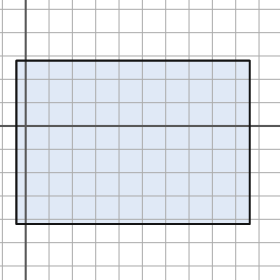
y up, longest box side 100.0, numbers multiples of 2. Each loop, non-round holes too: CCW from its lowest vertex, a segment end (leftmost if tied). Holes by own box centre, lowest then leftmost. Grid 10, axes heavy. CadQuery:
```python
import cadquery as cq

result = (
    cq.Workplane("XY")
    .moveTo(-4.0, -42.0)
    .lineTo(96.0, -42.0)
    .lineTo(96.0, 28.0)
    .lineTo(-4.0, 28.0)
    .close()
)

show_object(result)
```